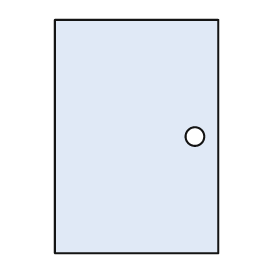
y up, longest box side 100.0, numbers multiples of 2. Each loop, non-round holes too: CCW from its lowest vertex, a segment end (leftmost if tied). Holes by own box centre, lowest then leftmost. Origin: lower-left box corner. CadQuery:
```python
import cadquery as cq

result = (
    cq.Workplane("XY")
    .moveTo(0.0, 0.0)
    .lineTo(70.0, 0.0)
    .lineTo(70.0, 100.0)
    .lineTo(0.0, 100.0)
    .close()
    .moveTo(60.0, 50.0)
    .circle(4.0)
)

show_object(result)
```